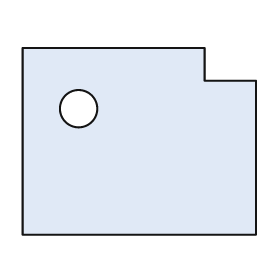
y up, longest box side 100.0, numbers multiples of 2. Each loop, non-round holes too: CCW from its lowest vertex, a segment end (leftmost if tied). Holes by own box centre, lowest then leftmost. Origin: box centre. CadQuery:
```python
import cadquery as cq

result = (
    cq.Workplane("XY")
    .moveTo(-50.0, -40.0)
    .lineTo(50.0, -40.0)
    .lineTo(50.0, 26.0)
    .lineTo(28.0, 26.0)
    .lineTo(28.0, 40.0)
    .lineTo(-50.0, 40.0)
    .close()
    .moveTo(-26.0, 14.0)
    .circle(8.0)
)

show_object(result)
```